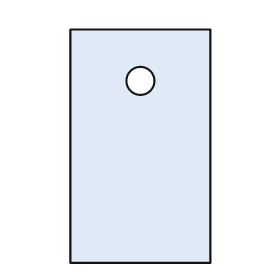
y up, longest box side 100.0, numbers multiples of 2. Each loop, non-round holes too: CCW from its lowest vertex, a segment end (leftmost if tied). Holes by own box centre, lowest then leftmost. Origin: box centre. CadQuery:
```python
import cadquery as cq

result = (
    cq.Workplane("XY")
    .moveTo(-30.0, -50.0)
    .lineTo(30.0, -50.0)
    .lineTo(30.0, 50.0)
    .lineTo(-30.0, 50.0)
    .close()
    .moveTo(0.0, 28.0)
    .circle(6.0)
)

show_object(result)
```